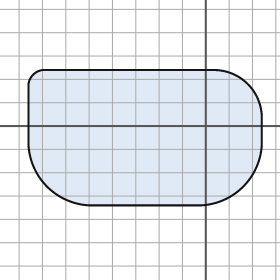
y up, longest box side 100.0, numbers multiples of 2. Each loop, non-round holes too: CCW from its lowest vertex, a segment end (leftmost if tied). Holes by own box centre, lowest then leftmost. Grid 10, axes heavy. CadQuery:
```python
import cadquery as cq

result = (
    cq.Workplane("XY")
    .moveTo(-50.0, -34.0)
    .lineTo(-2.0, -34.0)
    .threePointArc((16.0, -26.0), (24.0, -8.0))
    .lineTo(24.0, 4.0)
    .threePointArc((18.0, 18.0), (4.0, 24.0))
    .lineTo(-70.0, 24.0)
    .threePointArc((-74.0, 22.0), (-76.0, 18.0))
    .lineTo(-76.0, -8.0)
    .threePointArc((-68.0, -26.0), (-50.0, -34.0))
    .close()
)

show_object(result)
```